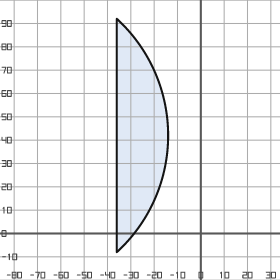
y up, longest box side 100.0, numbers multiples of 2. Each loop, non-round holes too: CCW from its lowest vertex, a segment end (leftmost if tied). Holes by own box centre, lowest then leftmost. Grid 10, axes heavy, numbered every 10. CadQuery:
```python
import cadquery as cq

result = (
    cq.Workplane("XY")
    .moveTo(-36.0, -8.0)
    .threePointArc((-14.0, 42.0), (-36.0, 92.0))
    .close()
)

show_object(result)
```